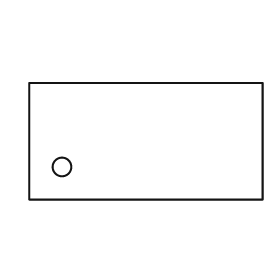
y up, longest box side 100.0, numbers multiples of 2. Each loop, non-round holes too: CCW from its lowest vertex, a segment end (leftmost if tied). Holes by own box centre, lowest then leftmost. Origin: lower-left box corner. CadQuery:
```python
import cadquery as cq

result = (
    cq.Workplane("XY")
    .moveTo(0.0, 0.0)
    .lineTo(100.0, 0.0)
    .lineTo(100.0, 50.0)
    .lineTo(0.0, 50.0)
    .close()
    .moveTo(14.0, 14.0)
    .circle(4.0)
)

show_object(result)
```